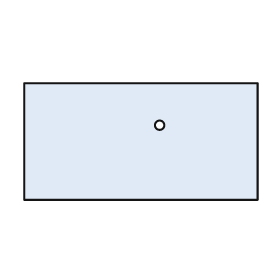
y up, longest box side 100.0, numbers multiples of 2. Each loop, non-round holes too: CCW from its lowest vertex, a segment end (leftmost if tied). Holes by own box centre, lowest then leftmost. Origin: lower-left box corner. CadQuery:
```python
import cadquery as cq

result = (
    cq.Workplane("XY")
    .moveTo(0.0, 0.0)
    .lineTo(100.0, 0.0)
    .lineTo(100.0, 50.0)
    .lineTo(0.0, 50.0)
    .close()
    .moveTo(58.0, 32.0)
    .circle(2.0)
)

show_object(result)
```